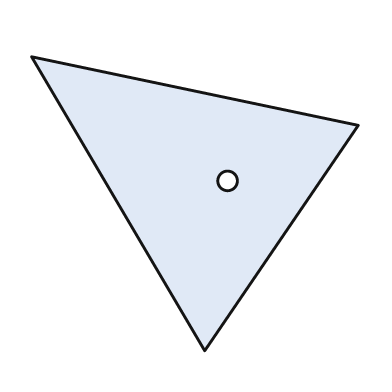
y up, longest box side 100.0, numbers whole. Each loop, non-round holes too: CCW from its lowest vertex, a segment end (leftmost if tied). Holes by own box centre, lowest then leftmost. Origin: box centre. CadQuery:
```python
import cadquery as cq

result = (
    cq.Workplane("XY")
    .moveTo(3.0, -45.0)
    .lineTo(50.0, 24.0)
    .lineTo(-50.0, 45.0)
    .close()
    .moveTo(10.0, 7.0)
    .circle(3.0)
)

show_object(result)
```